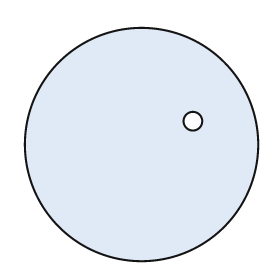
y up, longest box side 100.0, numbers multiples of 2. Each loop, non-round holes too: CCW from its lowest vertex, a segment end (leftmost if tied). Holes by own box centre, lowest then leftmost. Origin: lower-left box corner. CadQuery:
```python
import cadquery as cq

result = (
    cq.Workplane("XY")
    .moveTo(50.0, 50.0)
    .circle(50.0)
    .moveTo(72.0, 60.0)
    .circle(4.0)
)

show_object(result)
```